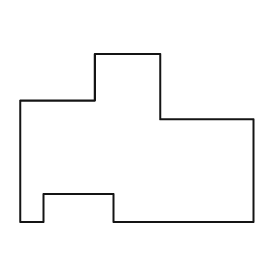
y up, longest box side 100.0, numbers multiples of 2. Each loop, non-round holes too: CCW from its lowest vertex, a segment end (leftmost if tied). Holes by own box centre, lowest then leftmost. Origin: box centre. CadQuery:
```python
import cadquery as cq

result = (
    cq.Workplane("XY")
    .moveTo(-50.0, -36.0)
    .lineTo(-40.0, -36.0)
    .lineTo(-40.0, -24.0)
    .lineTo(-10.0, -24.0)
    .lineTo(-10.0, -36.0)
    .lineTo(50.0, -36.0)
    .lineTo(50.0, 8.0)
    .lineTo(10.0, 8.0)
    .lineTo(10.0, 36.0)
    .lineTo(-18.0, 36.0)
    .lineTo(-18.0, 16.0)
    .lineTo(-50.0, 16.0)
    .close()
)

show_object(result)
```